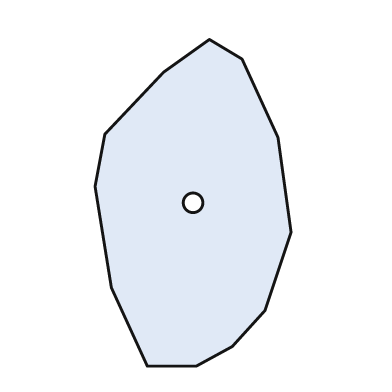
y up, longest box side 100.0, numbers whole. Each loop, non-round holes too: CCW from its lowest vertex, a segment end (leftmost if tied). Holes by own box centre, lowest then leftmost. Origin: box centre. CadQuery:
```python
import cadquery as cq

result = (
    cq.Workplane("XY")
    .moveTo(-14.0, -50.0)
    .lineTo(1.0, -50.0)
    .lineTo(12.0, -44.0)
    .lineTo(22.0, -33.0)
    .lineTo(30.0, -9.0)
    .lineTo(26.0, 20.0)
    .lineTo(15.0, 44.0)
    .lineTo(5.0, 50.0)
    .lineTo(-9.0, 40.0)
    .lineTo(-27.0, 21.0)
    .lineTo(-30.0, 5.0)
    .lineTo(-25.0, -26.0)
    .close()
    .moveTo(0.0, 0.0)
    .circle(3.0)
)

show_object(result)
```